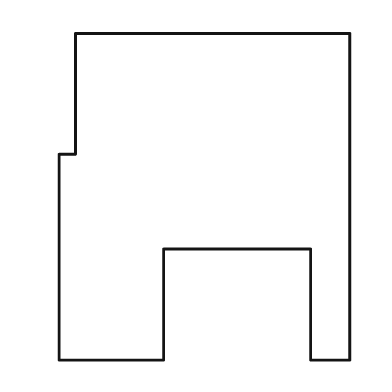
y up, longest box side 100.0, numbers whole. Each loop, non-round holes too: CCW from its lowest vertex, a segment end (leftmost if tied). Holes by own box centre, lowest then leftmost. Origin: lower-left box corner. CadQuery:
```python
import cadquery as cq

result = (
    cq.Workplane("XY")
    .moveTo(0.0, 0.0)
    .lineTo(32.0, 0.0)
    .lineTo(32.0, 34.0)
    .lineTo(77.0, 34.0)
    .lineTo(77.0, 0.0)
    .lineTo(89.0, 0.0)
    .lineTo(89.0, 100.0)
    .lineTo(5.0, 100.0)
    .lineTo(5.0, 63.0)
    .lineTo(0.0, 63.0)
    .close()
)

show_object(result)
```